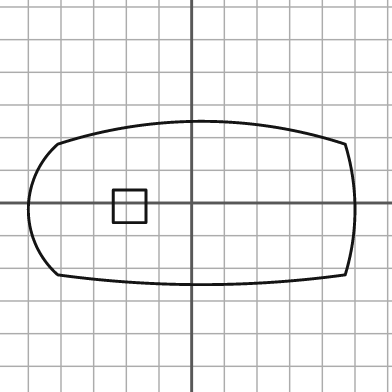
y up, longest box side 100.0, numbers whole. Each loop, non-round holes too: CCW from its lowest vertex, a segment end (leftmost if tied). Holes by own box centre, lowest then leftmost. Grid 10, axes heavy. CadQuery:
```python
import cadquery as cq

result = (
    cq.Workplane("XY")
    .moveTo(-41.0, -22.0)
    .threePointArc((3.0, -25.0), (47.0, -22.0))
    .threePointArc((50.0, -2.0), (47.0, 18.0))
    .threePointArc((3.0, 25.0), (-41.0, 18.0))
    .threePointArc((-50.0, -2.0), (-41.0, -22.0))
    .close()
    .moveTo(-24.0, -6.0)
    .lineTo(-14.0, -6.0)
    .lineTo(-14.0, 4.0)
    .lineTo(-24.0, 4.0)
    .close()
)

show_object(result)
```